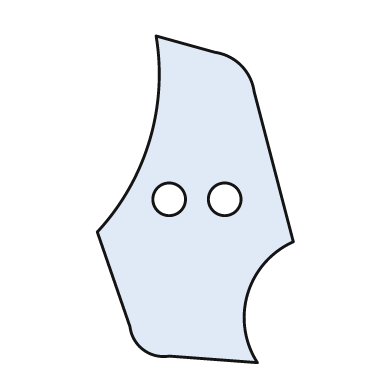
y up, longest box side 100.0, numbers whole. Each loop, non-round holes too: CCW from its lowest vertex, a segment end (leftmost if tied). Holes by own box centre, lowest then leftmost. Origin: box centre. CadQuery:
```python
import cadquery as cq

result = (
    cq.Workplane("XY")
    .moveTo(19.0, -50.0)
    .threePointArc((16.0, -29.0), (30.0, -13.0))
    .lineTo(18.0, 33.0)
    .threePointArc((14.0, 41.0), (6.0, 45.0))
    .lineTo(-12.0, 50.0)
    .threePointArc((-14.0, 18.0), (-30.0, -10.0))
    .lineTo(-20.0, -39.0)
    .threePointArc((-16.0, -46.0), (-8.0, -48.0))
    .close()
    .moveTo(-8.0, 0.0)
    .circle(5.0)
    .moveTo(9.0, 0.0)
    .circle(5.0)
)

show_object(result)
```